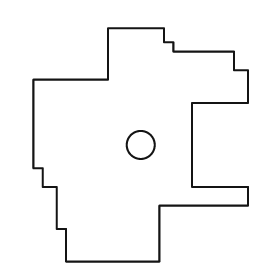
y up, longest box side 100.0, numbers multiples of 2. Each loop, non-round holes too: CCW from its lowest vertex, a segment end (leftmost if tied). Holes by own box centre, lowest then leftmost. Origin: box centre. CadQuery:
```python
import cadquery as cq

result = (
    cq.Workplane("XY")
    .moveTo(-32.0, -50.0)
    .lineTo(8.0, -50.0)
    .lineTo(8.0, -26.0)
    .lineTo(46.0, -26.0)
    .lineTo(46.0, -18.0)
    .lineTo(22.0, -18.0)
    .lineTo(22.0, 18.0)
    .lineTo(46.0, 18.0)
    .lineTo(46.0, 32.0)
    .lineTo(40.0, 32.0)
    .lineTo(40.0, 40.0)
    .lineTo(14.0, 40.0)
    .lineTo(14.0, 44.0)
    .lineTo(10.0, 44.0)
    .lineTo(10.0, 50.0)
    .lineTo(-14.0, 50.0)
    .lineTo(-14.0, 28.0)
    .lineTo(-46.0, 28.0)
    .lineTo(-46.0, -10.0)
    .lineTo(-42.0, -10.0)
    .lineTo(-42.0, -18.0)
    .lineTo(-36.0, -18.0)
    .lineTo(-36.0, -36.0)
    .lineTo(-32.0, -36.0)
    .close()
    .moveTo(0.0, 0.0)
    .circle(6.0)
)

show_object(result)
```